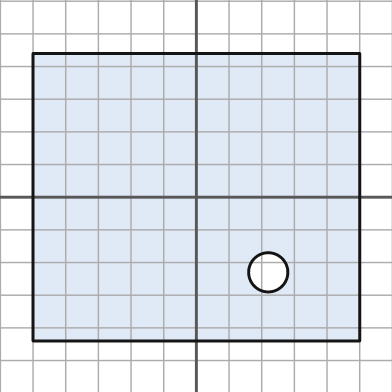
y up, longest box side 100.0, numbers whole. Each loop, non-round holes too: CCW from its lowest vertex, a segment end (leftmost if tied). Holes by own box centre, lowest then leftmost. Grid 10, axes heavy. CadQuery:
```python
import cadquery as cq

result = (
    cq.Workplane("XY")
    .moveTo(-50.0, -44.0)
    .lineTo(50.0, -44.0)
    .lineTo(50.0, 44.0)
    .lineTo(-50.0, 44.0)
    .close()
    .moveTo(22.0, -23.0)
    .circle(6.0)
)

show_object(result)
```